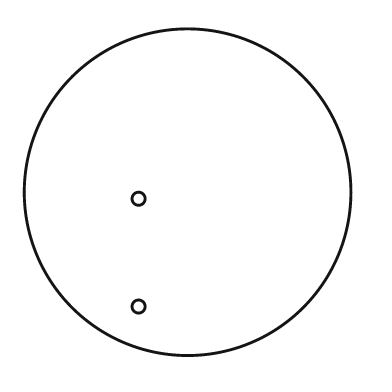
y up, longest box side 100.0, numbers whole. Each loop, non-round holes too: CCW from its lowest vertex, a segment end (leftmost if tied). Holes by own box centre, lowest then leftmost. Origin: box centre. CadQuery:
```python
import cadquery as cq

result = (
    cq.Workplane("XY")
    .moveTo(0.0, 0.0)
    .circle(50.0)
    .moveTo(-15.0, -35.0)
    .circle(2.0)
    .moveTo(-15.0, -2.0)
    .circle(2.0)
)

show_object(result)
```